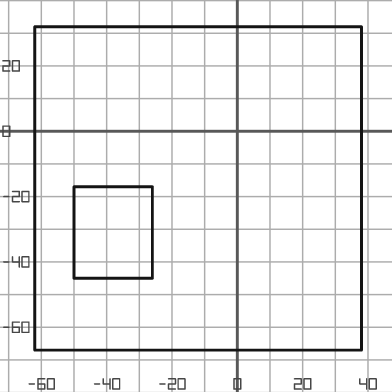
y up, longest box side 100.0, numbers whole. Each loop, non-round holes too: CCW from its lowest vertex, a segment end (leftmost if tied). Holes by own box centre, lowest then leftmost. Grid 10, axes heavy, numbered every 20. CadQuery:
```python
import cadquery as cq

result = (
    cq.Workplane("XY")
    .moveTo(-62.0, -67.0)
    .lineTo(38.0, -67.0)
    .lineTo(38.0, 32.0)
    .lineTo(-62.0, 32.0)
    .close()
    .moveTo(-50.0, -45.0)
    .lineTo(-26.0, -45.0)
    .lineTo(-26.0, -17.0)
    .lineTo(-50.0, -17.0)
    .close()
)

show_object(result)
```